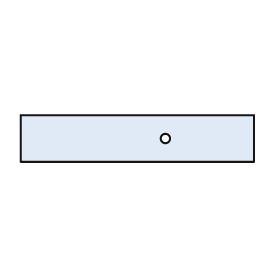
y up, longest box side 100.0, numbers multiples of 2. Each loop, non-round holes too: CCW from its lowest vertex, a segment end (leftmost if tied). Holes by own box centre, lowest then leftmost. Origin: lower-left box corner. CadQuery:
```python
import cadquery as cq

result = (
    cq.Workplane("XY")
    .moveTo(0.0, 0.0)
    .lineTo(100.0, 0.0)
    .lineTo(100.0, 20.0)
    .lineTo(0.0, 20.0)
    .close()
    .moveTo(62.0, 10.0)
    .circle(2.0)
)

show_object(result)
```